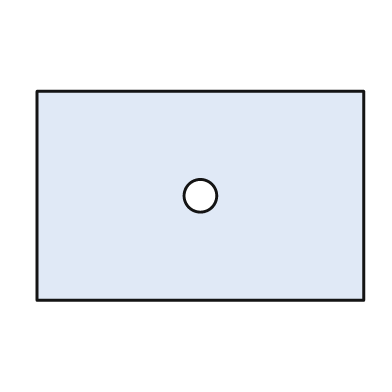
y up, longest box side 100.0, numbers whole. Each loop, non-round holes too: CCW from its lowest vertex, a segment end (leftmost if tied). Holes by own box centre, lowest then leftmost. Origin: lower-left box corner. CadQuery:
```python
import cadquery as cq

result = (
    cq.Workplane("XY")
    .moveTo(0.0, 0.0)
    .lineTo(100.0, 0.0)
    .lineTo(100.0, 64.0)
    .lineTo(0.0, 64.0)
    .close()
    .moveTo(50.0, 32.0)
    .circle(5.0)
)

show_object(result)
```